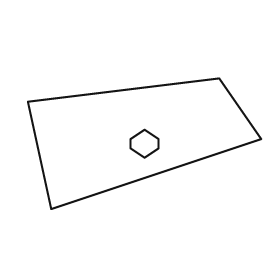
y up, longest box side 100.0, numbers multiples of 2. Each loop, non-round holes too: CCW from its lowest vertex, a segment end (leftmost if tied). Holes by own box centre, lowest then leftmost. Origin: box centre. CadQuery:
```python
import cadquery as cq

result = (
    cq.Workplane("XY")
    .moveTo(-40.0, -28.0)
    .lineTo(50.0, 2.0)
    .lineTo(32.0, 28.0)
    .lineTo(-50.0, 18.0)
    .close()
    .moveTo(0.0, -6.0)
    .lineTo(6.0, -2.0)
    .lineTo(6.0, 2.0)
    .lineTo(0.0, 6.0)
    .lineTo(-6.0, 2.0)
    .lineTo(-6.0, -2.0)
    .close()
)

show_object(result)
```